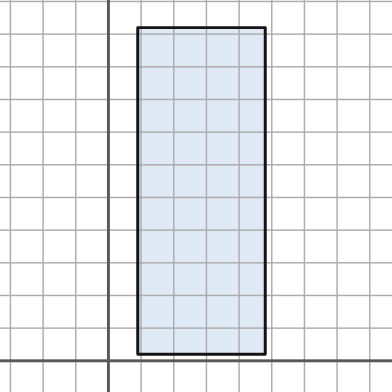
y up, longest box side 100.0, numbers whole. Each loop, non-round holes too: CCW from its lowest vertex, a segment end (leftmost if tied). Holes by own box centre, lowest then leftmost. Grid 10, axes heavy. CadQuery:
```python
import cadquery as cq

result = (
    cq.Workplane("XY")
    .moveTo(9.0, 2.0)
    .lineTo(48.0, 2.0)
    .lineTo(48.0, 102.0)
    .lineTo(9.0, 102.0)
    .close()
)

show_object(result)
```